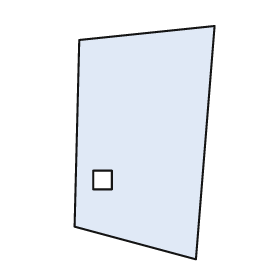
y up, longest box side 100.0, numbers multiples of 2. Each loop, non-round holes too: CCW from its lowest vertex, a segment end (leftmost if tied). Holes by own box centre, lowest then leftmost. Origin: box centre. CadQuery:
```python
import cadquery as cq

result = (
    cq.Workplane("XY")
    .moveTo(22.0, -50.0)
    .lineTo(30.0, 50.0)
    .lineTo(-28.0, 44.0)
    .lineTo(-30.0, -36.0)
    .close()
    .moveTo(-22.0, -20.0)
    .lineTo(-14.0, -20.0)
    .lineTo(-14.0, -12.0)
    .lineTo(-22.0, -12.0)
    .close()
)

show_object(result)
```